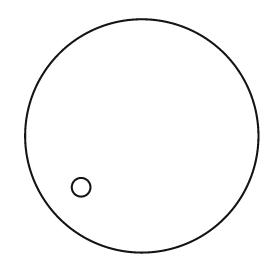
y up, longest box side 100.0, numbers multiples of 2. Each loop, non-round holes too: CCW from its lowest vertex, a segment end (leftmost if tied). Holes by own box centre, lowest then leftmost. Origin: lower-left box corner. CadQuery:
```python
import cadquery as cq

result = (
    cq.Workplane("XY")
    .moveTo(50.0, 50.0)
    .circle(50.0)
    .moveTo(24.0, 28.0)
    .circle(4.0)
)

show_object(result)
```